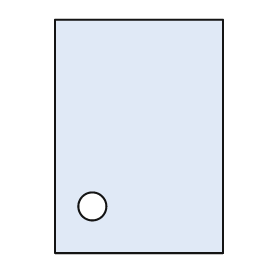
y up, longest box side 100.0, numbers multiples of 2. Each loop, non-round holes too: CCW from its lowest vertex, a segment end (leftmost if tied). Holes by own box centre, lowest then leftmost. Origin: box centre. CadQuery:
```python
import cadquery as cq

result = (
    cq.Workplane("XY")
    .moveTo(-36.0, -50.0)
    .lineTo(36.0, -50.0)
    .lineTo(36.0, 50.0)
    .lineTo(-36.0, 50.0)
    .close()
    .moveTo(-20.0, -30.0)
    .circle(6.0)
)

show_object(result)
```